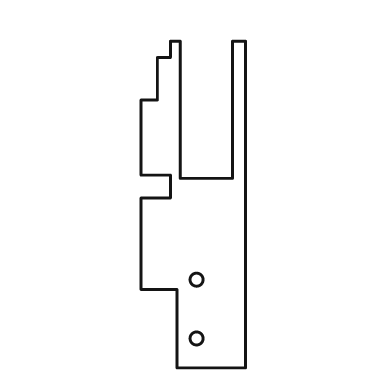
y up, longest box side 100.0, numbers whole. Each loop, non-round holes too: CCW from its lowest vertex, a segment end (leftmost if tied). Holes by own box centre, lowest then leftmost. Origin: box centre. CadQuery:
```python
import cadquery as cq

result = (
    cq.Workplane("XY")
    .moveTo(-5.0, -50.0)
    .lineTo(16.0, -50.0)
    .lineTo(16.0, 50.0)
    .lineTo(12.0, 50.0)
    .lineTo(12.0, 8.0)
    .lineTo(-4.0, 8.0)
    .lineTo(-4.0, 50.0)
    .lineTo(-7.0, 50.0)
    .lineTo(-7.0, 45.0)
    .lineTo(-11.0, 45.0)
    .lineTo(-11.0, 32.0)
    .lineTo(-16.0, 32.0)
    .lineTo(-16.0, 9.0)
    .lineTo(-7.0, 9.0)
    .lineTo(-7.0, 2.0)
    .lineTo(-16.0, 2.0)
    .lineTo(-16.0, -26.0)
    .lineTo(-5.0, -26.0)
    .close()
    .moveTo(1.0, -41.0)
    .circle(2.0)
    .moveTo(1.0, -23.0)
    .circle(2.0)
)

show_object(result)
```